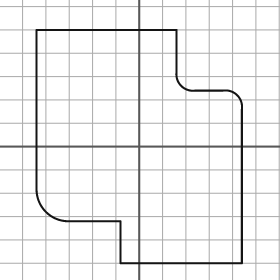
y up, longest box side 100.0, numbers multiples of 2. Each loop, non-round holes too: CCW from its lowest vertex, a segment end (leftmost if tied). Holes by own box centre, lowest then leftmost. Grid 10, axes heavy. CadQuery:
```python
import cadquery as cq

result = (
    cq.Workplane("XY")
    .moveTo(-8.0, -50.0)
    .lineTo(44.0, -50.0)
    .lineTo(44.0, 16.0)
    .threePointArc((42.0, 22.0), (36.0, 24.0))
    .lineTo(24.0, 24.0)
    .threePointArc((18.0, 26.0), (16.0, 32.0))
    .lineTo(16.0, 50.0)
    .lineTo(-44.0, 50.0)
    .lineTo(-44.0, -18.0)
    .threePointArc((-40.0, -28.0), (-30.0, -32.0))
    .lineTo(-8.0, -32.0)
    .close()
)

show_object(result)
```